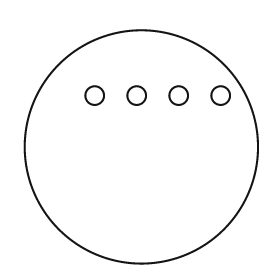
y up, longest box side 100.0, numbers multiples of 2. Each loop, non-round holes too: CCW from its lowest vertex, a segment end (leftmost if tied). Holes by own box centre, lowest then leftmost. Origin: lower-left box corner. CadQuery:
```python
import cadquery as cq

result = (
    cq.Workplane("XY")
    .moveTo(50.0, 50.0)
    .circle(50.0)
    .moveTo(30.0, 72.0)
    .circle(4.0)
    .moveTo(48.0, 72.0)
    .circle(4.0)
    .moveTo(66.0, 72.0)
    .circle(4.0)
    .moveTo(84.0, 72.0)
    .circle(4.0)
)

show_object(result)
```